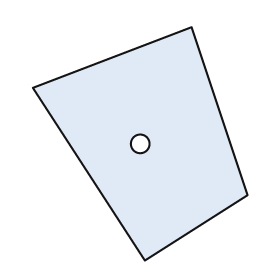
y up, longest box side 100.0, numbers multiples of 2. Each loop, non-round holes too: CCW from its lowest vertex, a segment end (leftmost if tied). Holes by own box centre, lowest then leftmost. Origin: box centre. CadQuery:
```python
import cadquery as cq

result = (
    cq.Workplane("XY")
    .moveTo(2.0, -50.0)
    .lineTo(46.0, -22.0)
    .lineTo(22.0, 50.0)
    .lineTo(-46.0, 24.0)
    .close()
    .moveTo(0.0, 0.0)
    .circle(4.0)
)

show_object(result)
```